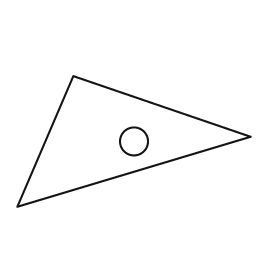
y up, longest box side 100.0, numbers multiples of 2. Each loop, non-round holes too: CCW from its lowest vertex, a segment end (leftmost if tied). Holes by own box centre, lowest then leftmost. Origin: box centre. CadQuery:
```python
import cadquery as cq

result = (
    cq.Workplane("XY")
    .moveTo(-50.0, -28.0)
    .lineTo(50.0, 2.0)
    .lineTo(-26.0, 28.0)
    .close()
    .moveTo(0.0, 0.0)
    .circle(6.0)
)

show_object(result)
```